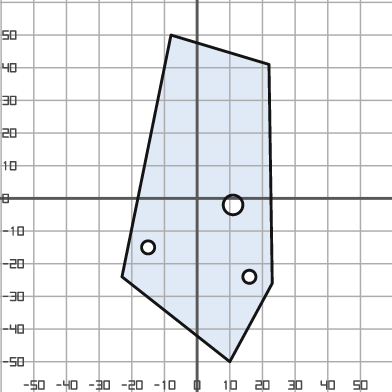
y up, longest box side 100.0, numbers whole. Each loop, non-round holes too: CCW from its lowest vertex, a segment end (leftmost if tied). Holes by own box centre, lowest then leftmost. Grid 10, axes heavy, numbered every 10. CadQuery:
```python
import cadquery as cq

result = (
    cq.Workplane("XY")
    .moveTo(10.0, -50.0)
    .lineTo(23.0, -26.0)
    .lineTo(22.0, 41.0)
    .lineTo(-8.0, 50.0)
    .lineTo(-23.0, -24.0)
    .close()
    .moveTo(16.0, -24.0)
    .circle(2.0)
    .moveTo(-15.0, -15.0)
    .circle(2.0)
    .moveTo(11.0, -2.0)
    .circle(3.0)
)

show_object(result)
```